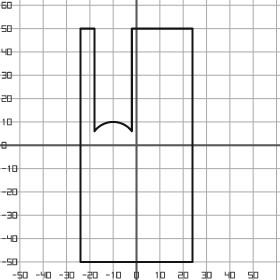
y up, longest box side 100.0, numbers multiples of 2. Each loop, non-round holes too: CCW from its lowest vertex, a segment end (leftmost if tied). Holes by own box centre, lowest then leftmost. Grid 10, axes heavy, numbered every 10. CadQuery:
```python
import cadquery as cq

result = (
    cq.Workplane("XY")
    .moveTo(-24.0, -50.0)
    .lineTo(24.0, -50.0)
    .lineTo(24.0, 50.0)
    .lineTo(-2.0, 50.0)
    .lineTo(-2.0, 6.0)
    .threePointArc((-10.0, 10.0), (-18.0, 6.0))
    .lineTo(-18.0, 50.0)
    .lineTo(-24.0, 50.0)
    .close()
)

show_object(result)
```